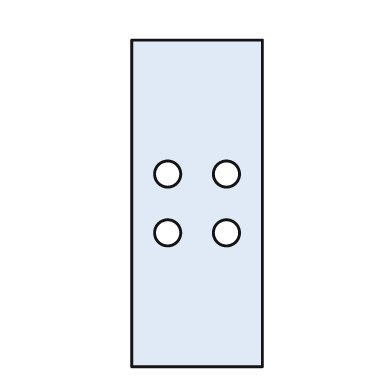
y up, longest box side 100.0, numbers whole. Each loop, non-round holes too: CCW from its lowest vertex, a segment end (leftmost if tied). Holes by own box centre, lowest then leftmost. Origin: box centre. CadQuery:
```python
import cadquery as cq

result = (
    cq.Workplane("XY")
    .moveTo(-20.0, -50.0)
    .lineTo(20.0, -50.0)
    .lineTo(20.0, 50.0)
    .lineTo(-20.0, 50.0)
    .close()
    .moveTo(-9.0, -9.0)
    .circle(4.0)
    .moveTo(9.0, -9.0)
    .circle(4.0)
    .moveTo(-9.0, 9.0)
    .circle(4.0)
    .moveTo(9.0, 9.0)
    .circle(4.0)
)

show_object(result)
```